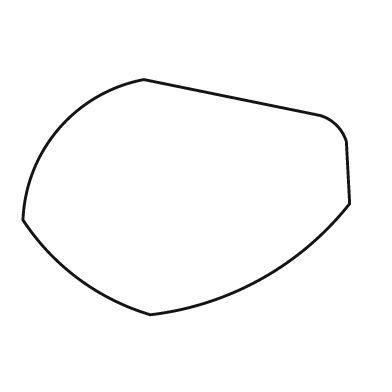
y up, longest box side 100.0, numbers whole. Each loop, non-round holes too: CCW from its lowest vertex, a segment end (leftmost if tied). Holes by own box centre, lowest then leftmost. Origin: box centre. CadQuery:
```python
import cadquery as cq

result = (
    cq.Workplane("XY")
    .moveTo(-11.0, -36.0)
    .threePointArc((23.0, -25.0), (50.0, -2.0))
    .lineTo(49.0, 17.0)
    .threePointArc((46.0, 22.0), (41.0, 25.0))
    .lineTo(-13.0, 36.0)
    .threePointArc((-39.0, 21.0), (-50.0, -7.0))
    .threePointArc((-33.0, -25.0), (-11.0, -36.0))
    .close()
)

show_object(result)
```